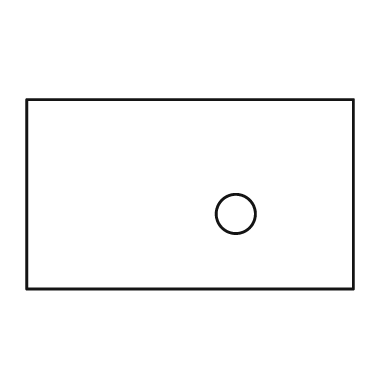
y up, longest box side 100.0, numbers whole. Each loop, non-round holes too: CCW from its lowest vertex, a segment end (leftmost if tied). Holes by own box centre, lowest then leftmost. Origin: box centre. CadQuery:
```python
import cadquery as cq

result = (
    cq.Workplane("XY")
    .moveTo(-50.0, -29.0)
    .lineTo(50.0, -29.0)
    .lineTo(50.0, 29.0)
    .lineTo(-50.0, 29.0)
    .close()
    .moveTo(14.0, -6.0)
    .circle(6.0)
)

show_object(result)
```